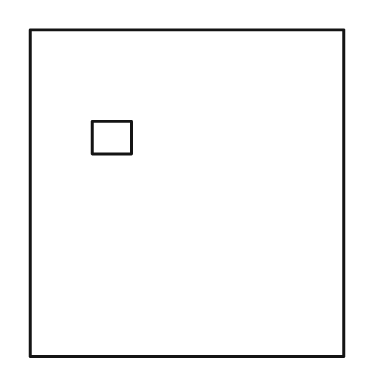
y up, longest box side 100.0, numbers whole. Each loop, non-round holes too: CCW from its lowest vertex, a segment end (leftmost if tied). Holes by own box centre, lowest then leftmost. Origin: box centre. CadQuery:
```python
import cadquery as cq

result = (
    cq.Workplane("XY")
    .moveTo(-48.0, -50.0)
    .lineTo(48.0, -50.0)
    .lineTo(48.0, 50.0)
    .lineTo(-48.0, 50.0)
    .close()
    .moveTo(-29.0, 12.0)
    .lineTo(-17.0, 12.0)
    .lineTo(-17.0, 22.0)
    .lineTo(-29.0, 22.0)
    .close()
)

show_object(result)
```